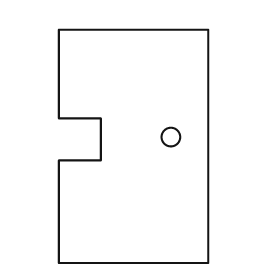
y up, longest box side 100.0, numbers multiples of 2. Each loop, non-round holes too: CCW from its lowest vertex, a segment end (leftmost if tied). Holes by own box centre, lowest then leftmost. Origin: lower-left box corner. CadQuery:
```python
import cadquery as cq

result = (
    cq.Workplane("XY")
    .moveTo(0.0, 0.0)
    .lineTo(64.0, 0.0)
    .lineTo(64.0, 100.0)
    .lineTo(0.0, 100.0)
    .lineTo(0.0, 62.0)
    .lineTo(18.0, 62.0)
    .lineTo(18.0, 44.0)
    .lineTo(0.0, 44.0)
    .close()
    .moveTo(48.0, 54.0)
    .circle(4.0)
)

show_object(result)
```